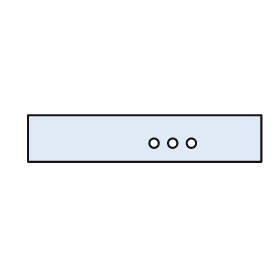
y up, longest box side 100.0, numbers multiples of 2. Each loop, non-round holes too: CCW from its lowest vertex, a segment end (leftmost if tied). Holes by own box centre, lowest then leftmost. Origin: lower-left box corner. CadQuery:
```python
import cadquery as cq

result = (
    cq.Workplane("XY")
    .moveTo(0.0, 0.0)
    .lineTo(100.0, 0.0)
    .lineTo(100.0, 20.0)
    .lineTo(0.0, 20.0)
    .close()
    .moveTo(54.0, 8.0)
    .circle(2.0)
    .moveTo(62.0, 8.0)
    .circle(2.0)
    .moveTo(70.0, 8.0)
    .circle(2.0)
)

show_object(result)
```